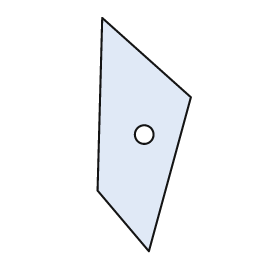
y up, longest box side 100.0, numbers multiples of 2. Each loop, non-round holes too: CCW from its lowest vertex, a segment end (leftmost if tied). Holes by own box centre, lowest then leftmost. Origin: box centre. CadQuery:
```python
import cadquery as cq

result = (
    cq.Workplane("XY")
    .moveTo(2.0, -50.0)
    .lineTo(20.0, 16.0)
    .lineTo(-18.0, 50.0)
    .lineTo(-20.0, -24.0)
    .close()
    .moveTo(0.0, 0.0)
    .circle(4.0)
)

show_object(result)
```